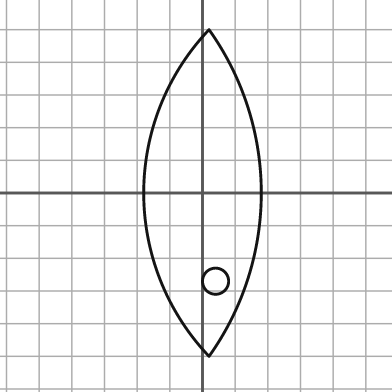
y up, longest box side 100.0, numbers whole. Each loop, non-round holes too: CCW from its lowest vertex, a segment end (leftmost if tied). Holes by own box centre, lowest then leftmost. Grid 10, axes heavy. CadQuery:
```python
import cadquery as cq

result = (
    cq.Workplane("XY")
    .moveTo(2.0, -50.0)
    .threePointArc((18.0, 0.0), (2.0, 50.0))
    .threePointArc((-18.0, 0.0), (2.0, -50.0))
    .close()
    .moveTo(4.0, -27.0)
    .circle(4.0)
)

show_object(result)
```